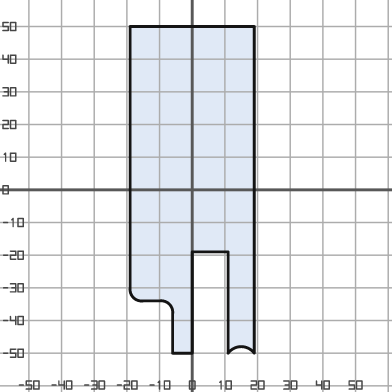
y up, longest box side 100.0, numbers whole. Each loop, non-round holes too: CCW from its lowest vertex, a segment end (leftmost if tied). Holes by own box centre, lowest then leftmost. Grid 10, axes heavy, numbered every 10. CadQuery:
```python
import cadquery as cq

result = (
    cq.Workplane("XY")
    .moveTo(-6.0, -50.0)
    .lineTo(0.0, -50.0)
    .lineTo(0.0, -19.0)
    .lineTo(11.0, -19.0)
    .lineTo(11.0, -50.0)
    .threePointArc((15.0, -48.0), (19.0, -50.0))
    .lineTo(19.0, 50.0)
    .lineTo(-19.0, 50.0)
    .lineTo(-19.0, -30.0)
    .threePointArc((-18.0, -33.0), (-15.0, -34.0))
    .lineTo(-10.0, -34.0)
    .threePointArc((-7.0, -35.0), (-6.0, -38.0))
    .close()
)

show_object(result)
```